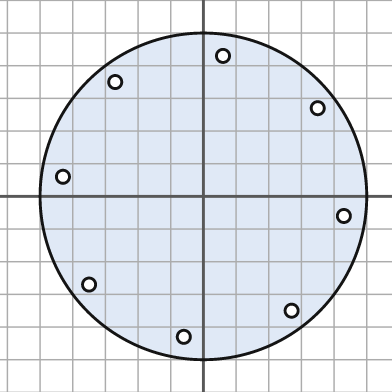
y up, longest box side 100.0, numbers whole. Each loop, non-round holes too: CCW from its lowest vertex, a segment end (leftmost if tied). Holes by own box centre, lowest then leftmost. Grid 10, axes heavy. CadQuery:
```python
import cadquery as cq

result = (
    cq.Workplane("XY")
    .moveTo(0.0, 0.0)
    .circle(50.0)
    .moveTo(-6.0, -43.0)
    .circle(2.0)
    .moveTo(27.0, -35.0)
    .circle(2.0)
    .moveTo(-35.0, -27.0)
    .circle(2.0)
    .moveTo(43.0, -6.0)
    .circle(2.0)
    .moveTo(-43.0, 6.0)
    .circle(2.0)
    .moveTo(35.0, 27.0)
    .circle(2.0)
    .moveTo(-27.0, 35.0)
    .circle(2.0)
    .moveTo(6.0, 43.0)
    .circle(2.0)
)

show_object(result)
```